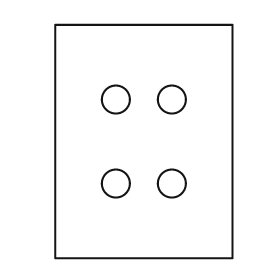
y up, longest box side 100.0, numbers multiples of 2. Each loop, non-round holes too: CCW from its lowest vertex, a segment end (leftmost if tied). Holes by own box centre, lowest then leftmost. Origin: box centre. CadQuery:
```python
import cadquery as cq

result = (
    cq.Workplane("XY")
    .moveTo(-38.0, -50.0)
    .lineTo(38.0, -50.0)
    .lineTo(38.0, 50.0)
    .lineTo(-38.0, 50.0)
    .close()
    .moveTo(-12.0, -18.0)
    .circle(6.0)
    .moveTo(12.0, -18.0)
    .circle(6.0)
    .moveTo(-12.0, 18.0)
    .circle(6.0)
    .moveTo(12.0, 18.0)
    .circle(6.0)
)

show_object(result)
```